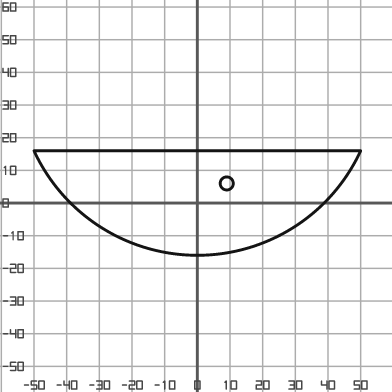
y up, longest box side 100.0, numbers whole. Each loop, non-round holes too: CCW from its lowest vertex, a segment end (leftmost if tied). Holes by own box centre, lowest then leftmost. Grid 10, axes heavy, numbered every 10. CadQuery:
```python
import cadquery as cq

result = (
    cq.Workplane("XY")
    .moveTo(-50.0, 16.0)
    .threePointArc((0.0, -16.0), (50.0, 16.0))
    .close()
    .moveTo(9.0, 6.0)
    .circle(2.0)
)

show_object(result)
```